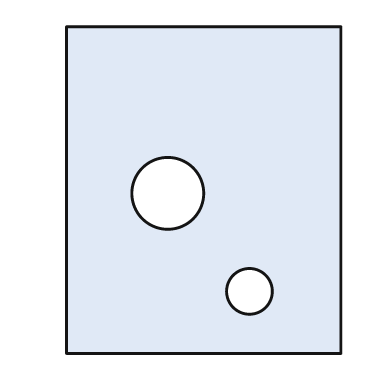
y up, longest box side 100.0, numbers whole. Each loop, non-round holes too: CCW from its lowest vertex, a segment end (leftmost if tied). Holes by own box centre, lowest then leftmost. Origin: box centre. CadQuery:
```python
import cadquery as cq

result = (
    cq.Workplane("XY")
    .moveTo(-42.0, -50.0)
    .lineTo(42.0, -50.0)
    .lineTo(42.0, 50.0)
    .lineTo(-42.0, 50.0)
    .close()
    .moveTo(14.0, -31.0)
    .circle(7.0)
    .moveTo(-11.0, -1.0)
    .circle(11.0)
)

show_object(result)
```